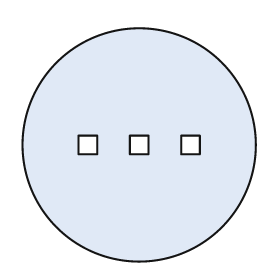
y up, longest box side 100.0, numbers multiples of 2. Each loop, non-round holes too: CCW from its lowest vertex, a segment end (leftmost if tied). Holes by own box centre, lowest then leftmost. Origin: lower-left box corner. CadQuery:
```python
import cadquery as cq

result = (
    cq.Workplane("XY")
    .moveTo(50.0, 50.0)
    .circle(50.0)
    .moveTo(24.0, 46.0)
    .lineTo(32.0, 46.0)
    .lineTo(32.0, 54.0)
    .lineTo(24.0, 54.0)
    .close()
    .moveTo(46.0, 46.0)
    .lineTo(54.0, 46.0)
    .lineTo(54.0, 54.0)
    .lineTo(46.0, 54.0)
    .close()
    .moveTo(68.0, 46.0)
    .lineTo(76.0, 46.0)
    .lineTo(76.0, 54.0)
    .lineTo(68.0, 54.0)
    .close()
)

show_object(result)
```